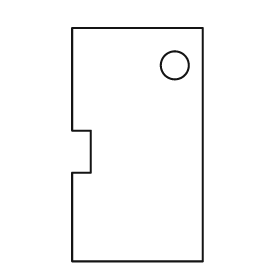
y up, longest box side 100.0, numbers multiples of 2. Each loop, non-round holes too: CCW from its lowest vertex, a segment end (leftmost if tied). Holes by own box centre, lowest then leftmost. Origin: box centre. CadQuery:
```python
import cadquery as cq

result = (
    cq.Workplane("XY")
    .moveTo(-28.0, -50.0)
    .lineTo(28.0, -50.0)
    .lineTo(28.0, 50.0)
    .lineTo(-28.0, 50.0)
    .lineTo(-28.0, 6.0)
    .lineTo(-20.0, 6.0)
    .lineTo(-20.0, -12.0)
    .lineTo(-28.0, -12.0)
    .close()
    .moveTo(16.0, 34.0)
    .circle(6.0)
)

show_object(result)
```